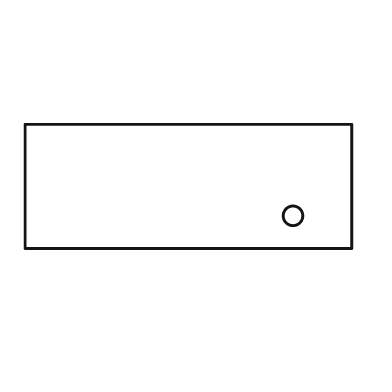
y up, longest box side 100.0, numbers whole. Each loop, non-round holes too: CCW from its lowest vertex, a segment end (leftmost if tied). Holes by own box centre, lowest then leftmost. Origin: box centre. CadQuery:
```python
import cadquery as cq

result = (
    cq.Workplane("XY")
    .moveTo(-50.0, -19.0)
    .lineTo(50.0, -19.0)
    .lineTo(50.0, 19.0)
    .lineTo(-50.0, 19.0)
    .close()
    .moveTo(32.0, -9.0)
    .circle(3.0)
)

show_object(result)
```